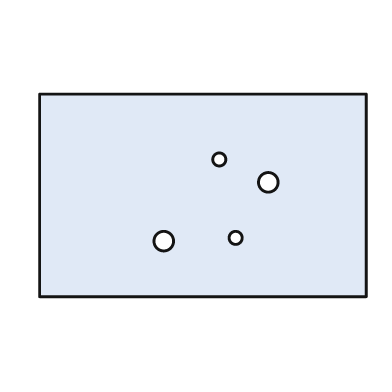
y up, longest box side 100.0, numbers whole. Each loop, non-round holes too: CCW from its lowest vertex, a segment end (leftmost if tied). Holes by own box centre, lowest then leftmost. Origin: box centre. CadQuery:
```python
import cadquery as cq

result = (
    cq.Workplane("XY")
    .moveTo(-50.0, -31.0)
    .lineTo(50.0, -31.0)
    .lineTo(50.0, 31.0)
    .lineTo(-50.0, 31.0)
    .close()
    .moveTo(-12.0, -14.0)
    .circle(3.0)
    .moveTo(10.0, -13.0)
    .circle(2.0)
    .moveTo(20.0, 4.0)
    .circle(3.0)
    .moveTo(5.0, 11.0)
    .circle(2.0)
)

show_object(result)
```